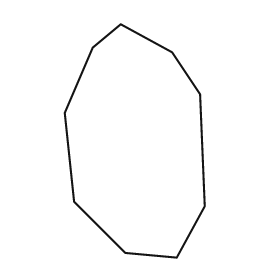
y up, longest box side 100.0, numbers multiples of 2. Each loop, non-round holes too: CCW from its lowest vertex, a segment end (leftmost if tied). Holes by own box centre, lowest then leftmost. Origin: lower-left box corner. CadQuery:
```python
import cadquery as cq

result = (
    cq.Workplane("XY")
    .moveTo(48.0, 0.0)
    .lineTo(60.0, 22.0)
    .lineTo(58.0, 70.0)
    .lineTo(46.0, 88.0)
    .lineTo(24.0, 100.0)
    .lineTo(12.0, 90.0)
    .lineTo(0.0, 62.0)
    .lineTo(4.0, 24.0)
    .lineTo(26.0, 2.0)
    .close()
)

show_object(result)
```